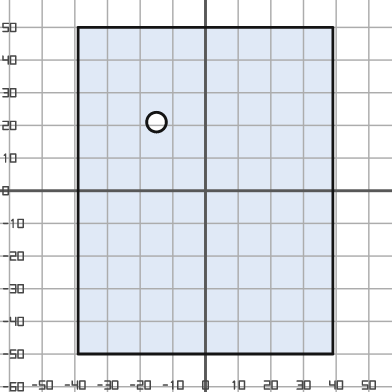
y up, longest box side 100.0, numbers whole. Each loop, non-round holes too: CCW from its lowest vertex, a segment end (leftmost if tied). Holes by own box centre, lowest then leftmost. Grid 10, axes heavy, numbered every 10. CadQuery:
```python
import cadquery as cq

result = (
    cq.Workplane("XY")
    .moveTo(-39.0, -50.0)
    .lineTo(39.0, -50.0)
    .lineTo(39.0, 50.0)
    .lineTo(-39.0, 50.0)
    .close()
    .moveTo(-15.0, 21.0)
    .circle(3.0)
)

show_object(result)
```